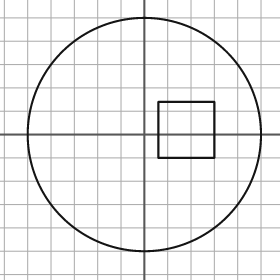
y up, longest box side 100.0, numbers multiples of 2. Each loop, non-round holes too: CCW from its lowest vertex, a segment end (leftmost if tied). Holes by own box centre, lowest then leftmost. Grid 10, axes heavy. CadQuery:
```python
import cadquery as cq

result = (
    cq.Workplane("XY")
    .moveTo(0.0, 0.0)
    .circle(50.0)
    .moveTo(6.0, -10.0)
    .lineTo(30.0, -10.0)
    .lineTo(30.0, 14.0)
    .lineTo(6.0, 14.0)
    .close()
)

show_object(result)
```